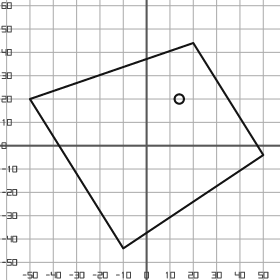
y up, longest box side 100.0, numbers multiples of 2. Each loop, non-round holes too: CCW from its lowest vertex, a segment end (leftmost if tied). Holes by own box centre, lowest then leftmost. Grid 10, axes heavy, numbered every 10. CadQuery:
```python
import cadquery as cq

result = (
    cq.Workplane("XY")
    .moveTo(-10.0, -44.0)
    .lineTo(50.0, -4.0)
    .lineTo(20.0, 44.0)
    .lineTo(-50.0, 20.0)
    .close()
    .moveTo(14.0, 20.0)
    .circle(2.0)
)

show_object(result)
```